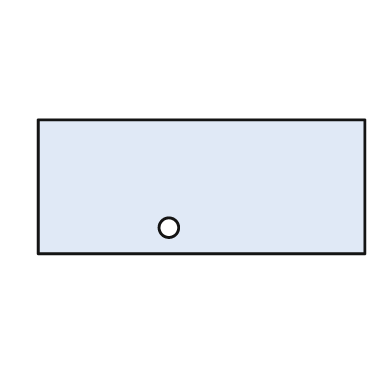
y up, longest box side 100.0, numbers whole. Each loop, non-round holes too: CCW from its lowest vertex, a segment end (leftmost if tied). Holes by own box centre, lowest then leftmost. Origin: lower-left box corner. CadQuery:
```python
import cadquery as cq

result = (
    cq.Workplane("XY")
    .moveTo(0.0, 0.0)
    .lineTo(100.0, 0.0)
    .lineTo(100.0, 41.0)
    .lineTo(0.0, 41.0)
    .close()
    .moveTo(40.0, 8.0)
    .circle(3.0)
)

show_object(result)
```